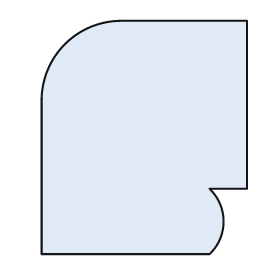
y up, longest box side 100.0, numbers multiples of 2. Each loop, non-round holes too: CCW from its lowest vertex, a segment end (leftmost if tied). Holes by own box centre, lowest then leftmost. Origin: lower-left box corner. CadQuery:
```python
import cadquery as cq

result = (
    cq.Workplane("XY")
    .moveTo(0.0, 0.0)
    .lineTo(72.0, 0.0)
    .threePointArc((78.0, 14.0), (72.0, 28.0))
    .lineTo(88.0, 28.0)
    .lineTo(88.0, 100.0)
    .lineTo(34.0, 100.0)
    .threePointArc((10.0, 90.0), (0.0, 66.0))
    .close()
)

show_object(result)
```